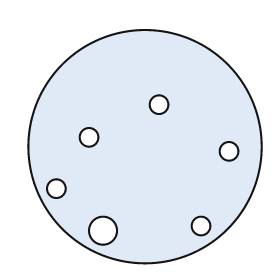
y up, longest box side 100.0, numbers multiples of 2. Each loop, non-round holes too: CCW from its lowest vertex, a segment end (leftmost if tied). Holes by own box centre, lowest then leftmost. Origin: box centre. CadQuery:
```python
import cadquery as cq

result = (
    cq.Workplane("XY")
    .moveTo(0.0, 0.0)
    .circle(50.0)
    .moveTo(-18.0, -36.0)
    .circle(6.0)
    .moveTo(24.0, -34.0)
    .circle(4.0)
    .moveTo(-38.0, -18.0)
    .circle(4.0)
    .moveTo(36.0, -2.0)
    .circle(4.0)
    .moveTo(-24.0, 4.0)
    .circle(4.0)
    .moveTo(6.0, 18.0)
    .circle(4.0)
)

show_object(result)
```